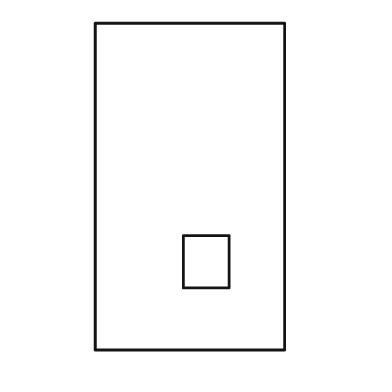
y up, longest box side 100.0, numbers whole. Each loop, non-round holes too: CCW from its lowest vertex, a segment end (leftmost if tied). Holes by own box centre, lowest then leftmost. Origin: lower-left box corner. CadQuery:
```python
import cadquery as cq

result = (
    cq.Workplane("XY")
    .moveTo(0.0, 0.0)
    .lineTo(58.0, 0.0)
    .lineTo(58.0, 100.0)
    .lineTo(0.0, 100.0)
    .close()
    .moveTo(27.0, 19.0)
    .lineTo(41.0, 19.0)
    .lineTo(41.0, 35.0)
    .lineTo(27.0, 35.0)
    .close()
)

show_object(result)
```